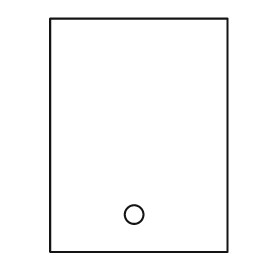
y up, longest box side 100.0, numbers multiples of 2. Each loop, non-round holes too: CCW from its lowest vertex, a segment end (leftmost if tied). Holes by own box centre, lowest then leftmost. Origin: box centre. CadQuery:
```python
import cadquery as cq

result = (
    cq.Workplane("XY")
    .moveTo(-38.0, -50.0)
    .lineTo(38.0, -50.0)
    .lineTo(38.0, 50.0)
    .lineTo(-38.0, 50.0)
    .close()
    .moveTo(-2.0, -34.0)
    .circle(4.0)
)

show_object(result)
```